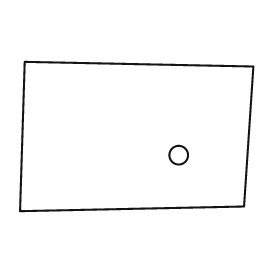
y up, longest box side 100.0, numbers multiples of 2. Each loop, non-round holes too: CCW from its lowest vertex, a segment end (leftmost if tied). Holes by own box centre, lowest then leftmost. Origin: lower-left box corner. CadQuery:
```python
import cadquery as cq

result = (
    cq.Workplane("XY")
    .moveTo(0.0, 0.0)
    .lineTo(96.0, 2.0)
    .lineTo(100.0, 62.0)
    .lineTo(2.0, 64.0)
    .close()
    .moveTo(68.0, 24.0)
    .circle(4.0)
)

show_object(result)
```